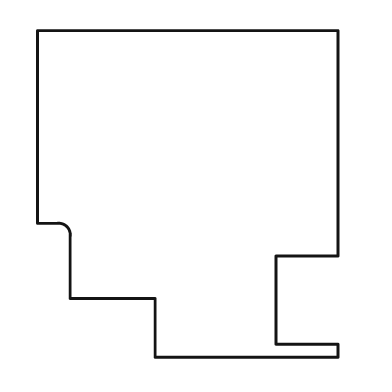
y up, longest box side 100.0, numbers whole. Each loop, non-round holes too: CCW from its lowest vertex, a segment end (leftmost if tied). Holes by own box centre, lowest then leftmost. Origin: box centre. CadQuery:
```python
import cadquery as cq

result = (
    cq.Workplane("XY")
    .moveTo(-10.0, -50.0)
    .lineTo(46.0, -50.0)
    .lineTo(46.0, -46.0)
    .lineTo(27.0, -46.0)
    .lineTo(27.0, -19.0)
    .lineTo(46.0, -19.0)
    .lineTo(46.0, 50.0)
    .lineTo(-46.0, 50.0)
    .lineTo(-46.0, -9.0)
    .lineTo(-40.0, -9.0)
    .threePointArc((-37.0, -10.0), (-36.0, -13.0))
    .lineTo(-36.0, -32.0)
    .lineTo(-10.0, -32.0)
    .close()
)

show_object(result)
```